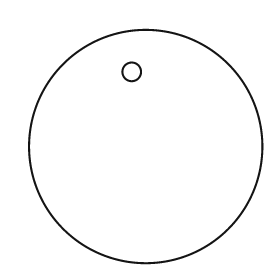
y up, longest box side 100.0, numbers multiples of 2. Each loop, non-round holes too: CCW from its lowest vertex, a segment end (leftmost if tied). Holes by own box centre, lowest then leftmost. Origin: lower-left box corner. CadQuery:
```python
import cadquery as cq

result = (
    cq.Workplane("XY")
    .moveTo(50.0, 50.0)
    .circle(50.0)
    .moveTo(44.0, 82.0)
    .circle(4.0)
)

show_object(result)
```